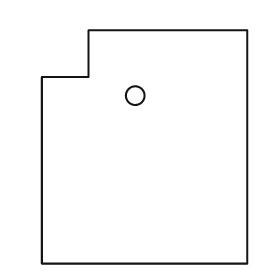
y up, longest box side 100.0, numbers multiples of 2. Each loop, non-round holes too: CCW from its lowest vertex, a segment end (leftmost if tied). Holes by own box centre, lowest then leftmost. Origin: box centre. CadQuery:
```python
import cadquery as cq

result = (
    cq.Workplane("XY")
    .moveTo(-44.0, -50.0)
    .lineTo(44.0, -50.0)
    .lineTo(44.0, 50.0)
    .lineTo(-24.0, 50.0)
    .lineTo(-24.0, 30.0)
    .lineTo(-44.0, 30.0)
    .close()
    .moveTo(-4.0, 22.0)
    .circle(4.0)
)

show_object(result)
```